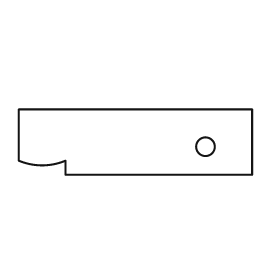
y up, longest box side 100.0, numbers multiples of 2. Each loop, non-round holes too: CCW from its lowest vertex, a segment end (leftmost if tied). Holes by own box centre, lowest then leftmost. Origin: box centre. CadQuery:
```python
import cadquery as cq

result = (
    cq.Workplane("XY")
    .moveTo(-30.0, -14.0)
    .lineTo(50.0, -14.0)
    .lineTo(50.0, 14.0)
    .lineTo(-50.0, 14.0)
    .lineTo(-50.0, -8.0)
    .threePointArc((-40.0, -10.0), (-30.0, -8.0))
    .close()
    .moveTo(30.0, -2.0)
    .circle(4.0)
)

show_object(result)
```